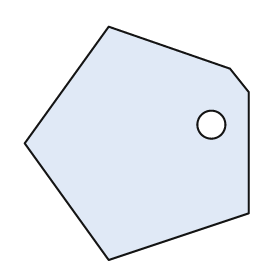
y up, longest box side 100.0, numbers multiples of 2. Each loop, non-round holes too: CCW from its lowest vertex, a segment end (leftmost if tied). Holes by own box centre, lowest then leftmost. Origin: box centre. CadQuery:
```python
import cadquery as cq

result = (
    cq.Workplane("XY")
    .moveTo(-12.0, -50.0)
    .lineTo(48.0, -30.0)
    .lineTo(48.0, 22.0)
    .lineTo(40.0, 32.0)
    .lineTo(-12.0, 50.0)
    .lineTo(-48.0, 0.0)
    .close()
    .moveTo(32.0, 8.0)
    .circle(6.0)
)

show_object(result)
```